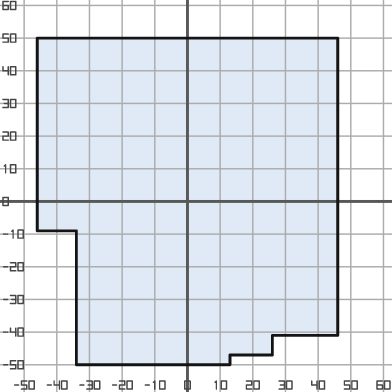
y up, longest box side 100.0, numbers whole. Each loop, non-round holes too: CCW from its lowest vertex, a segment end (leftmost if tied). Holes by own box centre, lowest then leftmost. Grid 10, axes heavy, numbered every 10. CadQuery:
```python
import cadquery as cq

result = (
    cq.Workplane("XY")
    .moveTo(-34.0, -50.0)
    .lineTo(13.0, -50.0)
    .lineTo(13.0, -47.0)
    .lineTo(26.0, -47.0)
    .lineTo(26.0, -41.0)
    .lineTo(46.0, -41.0)
    .lineTo(46.0, 50.0)
    .lineTo(-46.0, 50.0)
    .lineTo(-46.0, -9.0)
    .lineTo(-34.0, -9.0)
    .close()
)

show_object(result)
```